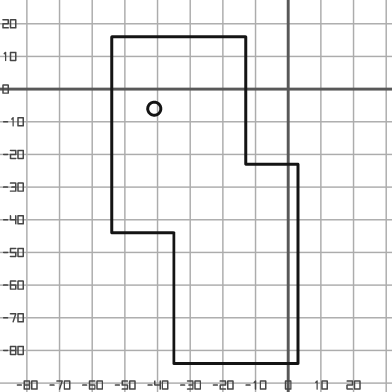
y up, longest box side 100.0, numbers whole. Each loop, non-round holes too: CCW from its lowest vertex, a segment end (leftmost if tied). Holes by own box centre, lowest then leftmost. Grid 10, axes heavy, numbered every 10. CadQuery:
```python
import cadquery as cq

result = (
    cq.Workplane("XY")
    .moveTo(-35.0, -84.0)
    .lineTo(3.0, -84.0)
    .lineTo(3.0, -23.0)
    .lineTo(-13.0, -23.0)
    .lineTo(-13.0, 16.0)
    .lineTo(-54.0, 16.0)
    .lineTo(-54.0, -44.0)
    .lineTo(-35.0, -44.0)
    .close()
    .moveTo(-41.0, -6.0)
    .circle(2.0)
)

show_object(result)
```